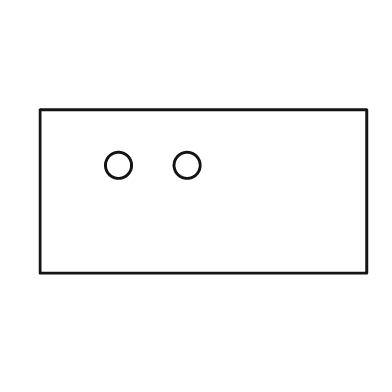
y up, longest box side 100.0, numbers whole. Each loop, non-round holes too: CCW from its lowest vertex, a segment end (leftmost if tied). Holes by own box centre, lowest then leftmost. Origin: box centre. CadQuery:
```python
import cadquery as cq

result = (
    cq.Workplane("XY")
    .moveTo(-50.0, -25.0)
    .lineTo(50.0, -25.0)
    .lineTo(50.0, 25.0)
    .lineTo(-50.0, 25.0)
    .close()
    .moveTo(-26.0, 8.0)
    .circle(4.0)
    .moveTo(-5.0, 8.0)
    .circle(4.0)
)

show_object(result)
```